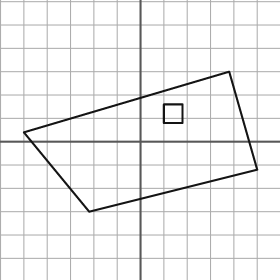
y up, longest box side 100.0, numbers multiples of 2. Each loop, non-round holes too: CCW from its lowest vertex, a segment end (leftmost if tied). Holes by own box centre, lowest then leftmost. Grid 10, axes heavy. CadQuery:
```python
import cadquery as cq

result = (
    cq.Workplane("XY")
    .moveTo(-22.0, -30.0)
    .lineTo(50.0, -12.0)
    .lineTo(38.0, 30.0)
    .lineTo(-50.0, 4.0)
    .close()
    .moveTo(10.0, 8.0)
    .lineTo(18.0, 8.0)
    .lineTo(18.0, 16.0)
    .lineTo(10.0, 16.0)
    .close()
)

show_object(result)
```